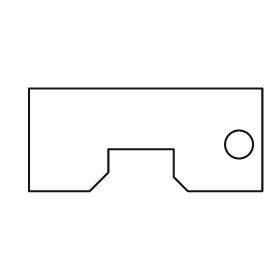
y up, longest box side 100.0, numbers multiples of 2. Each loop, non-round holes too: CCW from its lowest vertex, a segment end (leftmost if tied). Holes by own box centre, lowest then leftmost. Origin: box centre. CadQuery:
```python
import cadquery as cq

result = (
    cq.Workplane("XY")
    .moveTo(-50.0, -22.0)
    .lineTo(-24.0, -22.0)
    .lineTo(-16.0, -14.0)
    .lineTo(-16.0, -4.0)
    .lineTo(12.0, -4.0)
    .lineTo(12.0, -16.0)
    .lineTo(18.0, -22.0)
    .lineTo(50.0, -22.0)
    .lineTo(50.0, 22.0)
    .lineTo(-50.0, 22.0)
    .close()
    .moveTo(40.0, -2.0)
    .circle(6.0)
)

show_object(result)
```